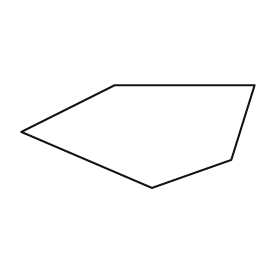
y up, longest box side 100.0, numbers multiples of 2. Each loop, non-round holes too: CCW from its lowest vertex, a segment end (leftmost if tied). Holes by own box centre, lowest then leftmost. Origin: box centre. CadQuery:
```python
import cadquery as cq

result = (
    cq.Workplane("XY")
    .moveTo(6.0, -22.0)
    .lineTo(40.0, -10.0)
    .lineTo(50.0, 22.0)
    .lineTo(-10.0, 22.0)
    .lineTo(-50.0, 2.0)
    .close()
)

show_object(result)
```